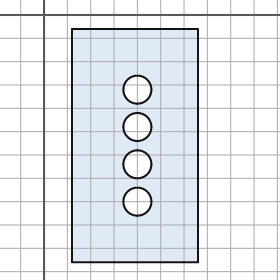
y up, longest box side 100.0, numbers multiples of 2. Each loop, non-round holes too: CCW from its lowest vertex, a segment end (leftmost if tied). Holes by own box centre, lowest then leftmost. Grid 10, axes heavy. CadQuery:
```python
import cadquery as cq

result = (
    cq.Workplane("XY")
    .moveTo(12.0, -106.0)
    .lineTo(66.0, -106.0)
    .lineTo(66.0, -6.0)
    .lineTo(12.0, -6.0)
    .close()
    .moveTo(40.0, -80.0)
    .circle(6.0)
    .moveTo(40.0, -64.0)
    .circle(6.0)
    .moveTo(40.0, -48.0)
    .circle(6.0)
    .moveTo(40.0, -32.0)
    .circle(6.0)
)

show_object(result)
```